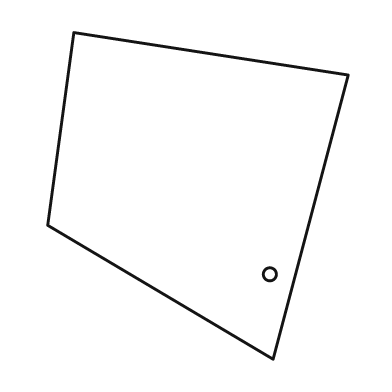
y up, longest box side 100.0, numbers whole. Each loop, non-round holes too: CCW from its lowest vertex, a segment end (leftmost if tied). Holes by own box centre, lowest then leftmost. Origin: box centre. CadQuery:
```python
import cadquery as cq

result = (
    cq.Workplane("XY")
    .moveTo(23.0, -50.0)
    .lineTo(46.0, 37.0)
    .lineTo(-38.0, 50.0)
    .lineTo(-46.0, -9.0)
    .close()
    .moveTo(22.0, -24.0)
    .circle(2.0)
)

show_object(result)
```